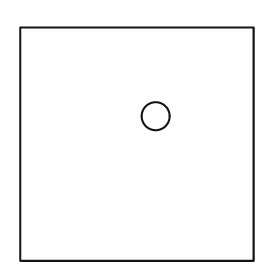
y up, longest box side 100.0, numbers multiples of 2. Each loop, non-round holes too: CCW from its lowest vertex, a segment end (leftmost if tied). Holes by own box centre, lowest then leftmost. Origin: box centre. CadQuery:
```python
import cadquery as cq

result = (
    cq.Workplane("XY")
    .moveTo(-50.0, -50.0)
    .lineTo(50.0, -50.0)
    .lineTo(50.0, 50.0)
    .lineTo(-50.0, 50.0)
    .close()
    .moveTo(8.0, 12.0)
    .circle(6.0)
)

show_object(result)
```